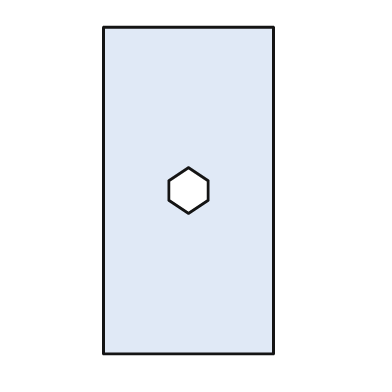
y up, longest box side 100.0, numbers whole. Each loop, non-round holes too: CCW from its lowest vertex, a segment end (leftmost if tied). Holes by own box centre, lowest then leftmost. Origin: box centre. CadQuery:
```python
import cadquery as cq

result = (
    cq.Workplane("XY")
    .moveTo(-26.0, -50.0)
    .lineTo(26.0, -50.0)
    .lineTo(26.0, 50.0)
    .lineTo(-26.0, 50.0)
    .close()
    .moveTo(0.0, -7.0)
    .lineTo(6.0, -3.0)
    .lineTo(6.0, 3.0)
    .lineTo(0.0, 7.0)
    .lineTo(-6.0, 3.0)
    .lineTo(-6.0, -3.0)
    .close()
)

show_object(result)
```